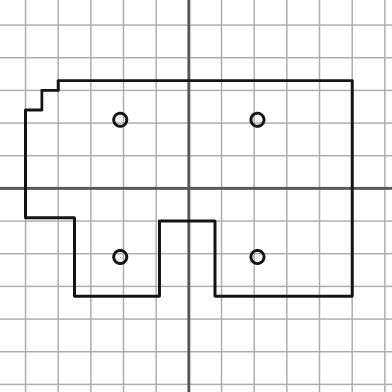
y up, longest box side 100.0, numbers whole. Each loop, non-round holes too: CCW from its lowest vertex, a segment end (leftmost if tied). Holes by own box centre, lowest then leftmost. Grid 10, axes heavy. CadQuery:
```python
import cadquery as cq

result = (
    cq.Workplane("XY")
    .moveTo(-35.0, -33.0)
    .lineTo(-9.0, -33.0)
    .lineTo(-9.0, -10.0)
    .lineTo(8.0, -10.0)
    .lineTo(8.0, -33.0)
    .lineTo(50.0, -33.0)
    .lineTo(50.0, 33.0)
    .lineTo(-40.0, 33.0)
    .lineTo(-40.0, 30.0)
    .lineTo(-45.0, 30.0)
    .lineTo(-45.0, 24.0)
    .lineTo(-50.0, 24.0)
    .lineTo(-50.0, -9.0)
    .lineTo(-35.0, -9.0)
    .close()
    .moveTo(-21.0, -21.0)
    .circle(2.0)
    .moveTo(21.0, -21.0)
    .circle(2.0)
    .moveTo(-21.0, 21.0)
    .circle(2.0)
    .moveTo(21.0, 21.0)
    .circle(2.0)
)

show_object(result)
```